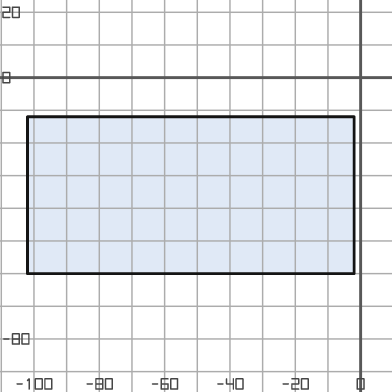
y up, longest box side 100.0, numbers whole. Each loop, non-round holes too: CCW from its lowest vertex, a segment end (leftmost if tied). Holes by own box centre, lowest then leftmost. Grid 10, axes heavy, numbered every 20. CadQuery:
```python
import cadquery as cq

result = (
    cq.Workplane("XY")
    .moveTo(-102.0, -60.0)
    .lineTo(-2.0, -60.0)
    .lineTo(-2.0, -12.0)
    .lineTo(-102.0, -12.0)
    .close()
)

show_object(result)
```